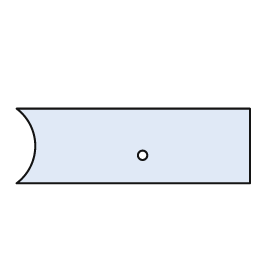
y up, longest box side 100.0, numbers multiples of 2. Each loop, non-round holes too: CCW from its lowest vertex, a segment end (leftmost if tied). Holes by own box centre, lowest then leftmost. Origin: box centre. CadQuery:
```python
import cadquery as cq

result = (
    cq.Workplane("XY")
    .moveTo(-50.0, -16.0)
    .lineTo(50.0, -16.0)
    .lineTo(50.0, 16.0)
    .lineTo(-50.0, 16.0)
    .threePointArc((-42.0, 0.0), (-50.0, -16.0))
    .close()
    .moveTo(4.0, -4.0)
    .circle(2.0)
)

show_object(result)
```